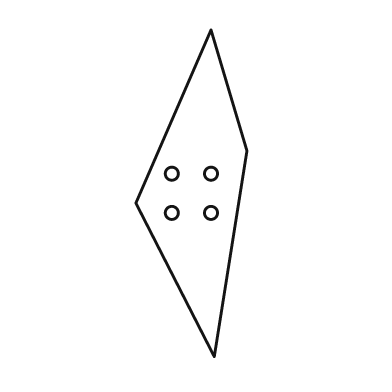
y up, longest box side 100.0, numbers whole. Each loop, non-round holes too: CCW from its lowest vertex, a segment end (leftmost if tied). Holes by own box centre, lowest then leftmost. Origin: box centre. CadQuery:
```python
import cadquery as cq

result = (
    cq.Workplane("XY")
    .moveTo(7.0, -50.0)
    .lineTo(17.0, 13.0)
    .lineTo(6.0, 50.0)
    .lineTo(-17.0, -3.0)
    .close()
    .moveTo(-6.0, -6.0)
    .circle(2.0)
    .moveTo(6.0, -6.0)
    .circle(2.0)
    .moveTo(-6.0, 6.0)
    .circle(2.0)
    .moveTo(6.0, 6.0)
    .circle(2.0)
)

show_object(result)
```